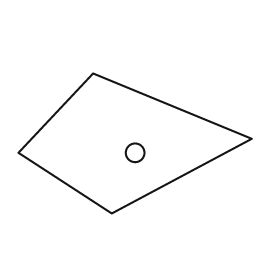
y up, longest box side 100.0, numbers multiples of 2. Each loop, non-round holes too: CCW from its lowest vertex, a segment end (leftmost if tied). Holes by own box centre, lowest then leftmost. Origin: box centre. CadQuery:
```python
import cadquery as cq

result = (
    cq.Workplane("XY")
    .moveTo(-10.0, -30.0)
    .lineTo(50.0, 2.0)
    .lineTo(-18.0, 30.0)
    .lineTo(-50.0, -4.0)
    .close()
    .moveTo(0.0, -4.0)
    .circle(4.0)
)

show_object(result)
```